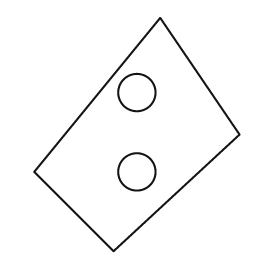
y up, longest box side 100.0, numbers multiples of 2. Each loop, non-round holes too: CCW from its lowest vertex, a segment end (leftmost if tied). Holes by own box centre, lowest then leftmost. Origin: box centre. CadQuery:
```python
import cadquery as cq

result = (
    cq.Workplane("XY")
    .moveTo(-10.0, -50.0)
    .lineTo(44.0, 0.0)
    .lineTo(10.0, 50.0)
    .lineTo(-44.0, -16.0)
    .close()
    .moveTo(0.0, -16.0)
    .circle(8.0)
    .moveTo(0.0, 18.0)
    .circle(8.0)
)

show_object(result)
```